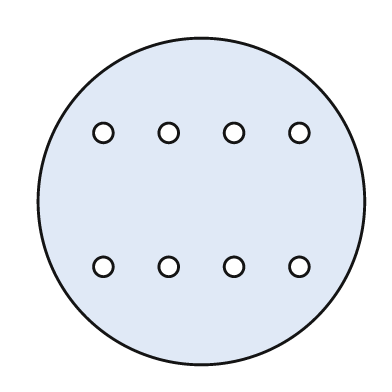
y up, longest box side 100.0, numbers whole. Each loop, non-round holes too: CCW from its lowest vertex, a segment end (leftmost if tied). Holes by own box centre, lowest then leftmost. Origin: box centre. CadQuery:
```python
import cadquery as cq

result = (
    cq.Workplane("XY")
    .moveTo(0.0, 0.0)
    .circle(50.0)
    .moveTo(-30.0, -20.0)
    .circle(3.0)
    .moveTo(-10.0, -20.0)
    .circle(3.0)
    .moveTo(10.0, -20.0)
    .circle(3.0)
    .moveTo(30.0, -20.0)
    .circle(3.0)
    .moveTo(-30.0, 21.0)
    .circle(3.0)
    .moveTo(-10.0, 21.0)
    .circle(3.0)
    .moveTo(10.0, 21.0)
    .circle(3.0)
    .moveTo(30.0, 21.0)
    .circle(3.0)
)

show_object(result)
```